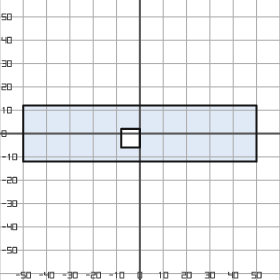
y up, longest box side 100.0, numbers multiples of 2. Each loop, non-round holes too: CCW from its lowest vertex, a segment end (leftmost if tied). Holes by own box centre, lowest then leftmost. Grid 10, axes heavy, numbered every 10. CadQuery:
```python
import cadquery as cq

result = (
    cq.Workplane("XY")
    .moveTo(-50.0, -12.0)
    .lineTo(50.0, -12.0)
    .lineTo(50.0, 12.0)
    .lineTo(-50.0, 12.0)
    .close()
    .moveTo(-8.0, -6.0)
    .lineTo(0.0, -6.0)
    .lineTo(0.0, 2.0)
    .lineTo(-8.0, 2.0)
    .close()
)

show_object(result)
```